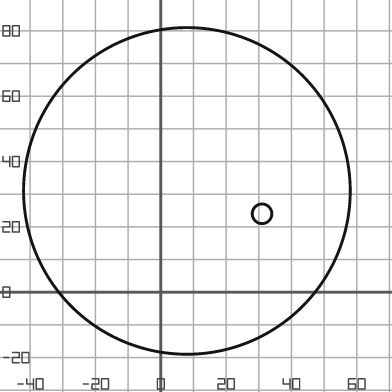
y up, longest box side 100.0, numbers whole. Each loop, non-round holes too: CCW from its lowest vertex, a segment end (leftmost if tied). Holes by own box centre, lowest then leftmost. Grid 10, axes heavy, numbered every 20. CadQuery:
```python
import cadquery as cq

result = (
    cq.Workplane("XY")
    .moveTo(8.0, 31.0)
    .circle(50.0)
    .moveTo(31.0, 24.0)
    .circle(3.0)
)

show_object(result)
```